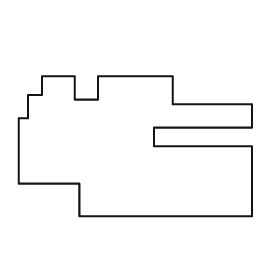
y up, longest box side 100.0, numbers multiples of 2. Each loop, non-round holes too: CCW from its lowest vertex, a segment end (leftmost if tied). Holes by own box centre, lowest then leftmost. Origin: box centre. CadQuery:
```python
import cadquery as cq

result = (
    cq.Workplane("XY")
    .moveTo(-24.0, -30.0)
    .lineTo(50.0, -30.0)
    .lineTo(50.0, 0.0)
    .lineTo(8.0, 0.0)
    .lineTo(8.0, 8.0)
    .lineTo(50.0, 8.0)
    .lineTo(50.0, 18.0)
    .lineTo(16.0, 18.0)
    .lineTo(16.0, 30.0)
    .lineTo(-16.0, 30.0)
    .lineTo(-16.0, 20.0)
    .lineTo(-26.0, 20.0)
    .lineTo(-26.0, 30.0)
    .lineTo(-40.0, 30.0)
    .lineTo(-40.0, 22.0)
    .lineTo(-46.0, 22.0)
    .lineTo(-46.0, 12.0)
    .lineTo(-50.0, 12.0)
    .lineTo(-50.0, -16.0)
    .lineTo(-24.0, -16.0)
    .close()
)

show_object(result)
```